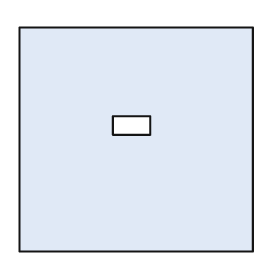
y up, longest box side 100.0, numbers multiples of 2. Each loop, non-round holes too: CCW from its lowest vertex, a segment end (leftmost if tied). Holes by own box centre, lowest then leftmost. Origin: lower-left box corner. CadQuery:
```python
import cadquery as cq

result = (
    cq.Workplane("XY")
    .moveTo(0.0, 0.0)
    .lineTo(100.0, 0.0)
    .lineTo(100.0, 96.0)
    .lineTo(0.0, 96.0)
    .close()
    .moveTo(40.0, 50.0)
    .lineTo(56.0, 50.0)
    .lineTo(56.0, 58.0)
    .lineTo(40.0, 58.0)
    .close()
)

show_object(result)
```